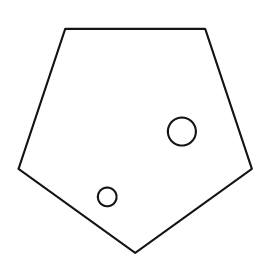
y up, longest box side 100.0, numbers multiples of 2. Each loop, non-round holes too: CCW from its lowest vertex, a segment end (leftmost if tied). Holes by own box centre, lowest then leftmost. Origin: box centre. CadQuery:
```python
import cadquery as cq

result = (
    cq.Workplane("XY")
    .moveTo(0.0, -48.0)
    .lineTo(50.0, -12.0)
    .lineTo(30.0, 48.0)
    .lineTo(-30.0, 48.0)
    .lineTo(-50.0, -12.0)
    .close()
    .moveTo(-12.0, -24.0)
    .circle(4.0)
    .moveTo(20.0, 4.0)
    .circle(6.0)
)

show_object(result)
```